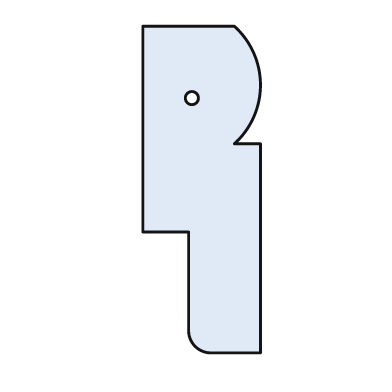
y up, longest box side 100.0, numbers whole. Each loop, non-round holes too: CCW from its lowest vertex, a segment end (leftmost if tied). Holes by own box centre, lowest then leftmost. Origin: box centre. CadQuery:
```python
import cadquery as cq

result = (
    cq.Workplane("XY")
    .moveTo(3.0, -50.0)
    .lineTo(18.0, -50.0)
    .lineTo(18.0, 14.0)
    .lineTo(10.0, 14.0)
    .threePointArc((18.0, 32.0), (10.0, 50.0))
    .lineTo(-18.0, 50.0)
    .lineTo(-18.0, -13.0)
    .lineTo(-4.0, -13.0)
    .lineTo(-4.0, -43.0)
    .threePointArc((-2.0, -48.0), (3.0, -50.0))
    .close()
    .moveTo(-3.0, 28.0)
    .circle(2.0)
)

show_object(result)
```